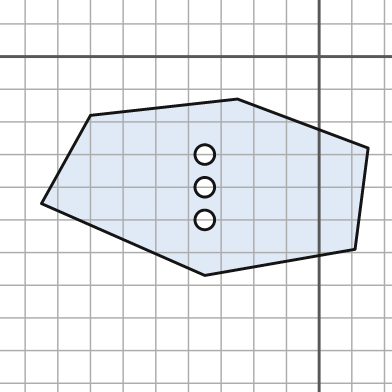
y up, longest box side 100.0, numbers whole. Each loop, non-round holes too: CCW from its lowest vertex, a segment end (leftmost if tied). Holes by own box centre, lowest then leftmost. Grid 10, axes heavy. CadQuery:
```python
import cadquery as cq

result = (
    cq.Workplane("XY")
    .moveTo(-35.0, -67.0)
    .lineTo(11.0, -59.0)
    .lineTo(15.0, -28.0)
    .lineTo(-25.0, -13.0)
    .lineTo(-70.0, -18.0)
    .lineTo(-85.0, -45.0)
    .close()
    .moveTo(-35.0, -50.0)
    .circle(3.0)
    .moveTo(-35.0, -40.0)
    .circle(3.0)
    .moveTo(-35.0, -30.0)
    .circle(3.0)
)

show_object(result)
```